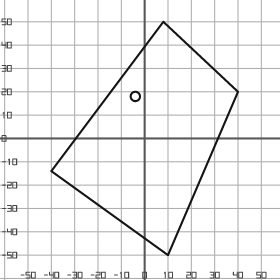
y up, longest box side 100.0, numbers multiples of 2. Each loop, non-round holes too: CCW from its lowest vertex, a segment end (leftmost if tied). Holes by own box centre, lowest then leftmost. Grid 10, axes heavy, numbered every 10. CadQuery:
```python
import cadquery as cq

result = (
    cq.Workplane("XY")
    .moveTo(10.0, -50.0)
    .lineTo(40.0, 20.0)
    .lineTo(8.0, 50.0)
    .lineTo(-40.0, -14.0)
    .close()
    .moveTo(-4.0, 18.0)
    .circle(2.0)
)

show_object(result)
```